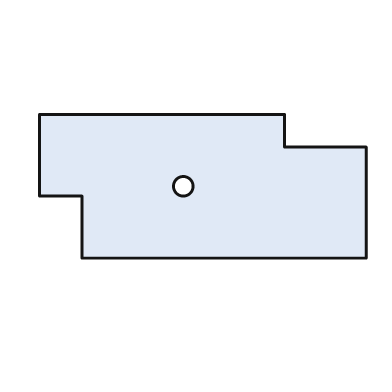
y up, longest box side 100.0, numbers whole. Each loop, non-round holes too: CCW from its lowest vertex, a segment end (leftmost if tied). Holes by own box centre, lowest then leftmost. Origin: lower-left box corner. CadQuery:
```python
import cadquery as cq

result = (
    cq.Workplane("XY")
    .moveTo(13.0, 0.0)
    .lineTo(100.0, 0.0)
    .lineTo(100.0, 34.0)
    .lineTo(75.0, 34.0)
    .lineTo(75.0, 44.0)
    .lineTo(0.0, 44.0)
    .lineTo(0.0, 19.0)
    .lineTo(13.0, 19.0)
    .close()
    .moveTo(44.0, 22.0)
    .circle(3.0)
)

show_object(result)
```